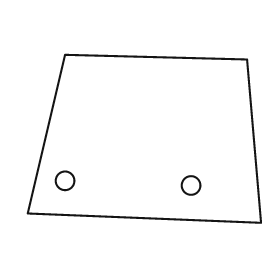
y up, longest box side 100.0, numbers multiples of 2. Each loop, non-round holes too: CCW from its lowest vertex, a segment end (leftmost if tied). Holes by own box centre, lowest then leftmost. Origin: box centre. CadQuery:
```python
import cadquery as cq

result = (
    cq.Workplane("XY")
    .moveTo(50.0, -36.0)
    .lineTo(44.0, 34.0)
    .lineTo(-34.0, 36.0)
    .lineTo(-50.0, -32.0)
    .close()
    .moveTo(20.0, -20.0)
    .circle(4.0)
    .moveTo(-34.0, -18.0)
    .circle(4.0)
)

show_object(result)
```